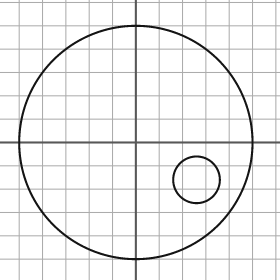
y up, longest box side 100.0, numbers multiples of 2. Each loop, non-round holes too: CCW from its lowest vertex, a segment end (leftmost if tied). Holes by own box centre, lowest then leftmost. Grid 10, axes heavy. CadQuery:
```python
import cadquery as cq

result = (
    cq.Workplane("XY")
    .moveTo(0.0, 0.0)
    .circle(50.0)
    .moveTo(26.0, -16.0)
    .circle(10.0)
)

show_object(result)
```